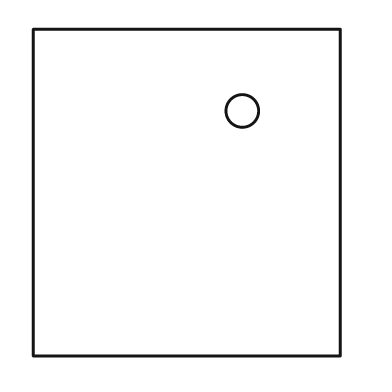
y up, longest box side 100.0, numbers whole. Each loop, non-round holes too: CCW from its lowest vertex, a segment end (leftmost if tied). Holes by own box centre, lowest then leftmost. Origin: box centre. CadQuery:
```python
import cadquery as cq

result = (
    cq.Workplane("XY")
    .moveTo(-47.0, -50.0)
    .lineTo(47.0, -50.0)
    .lineTo(47.0, 50.0)
    .lineTo(-47.0, 50.0)
    .close()
    .moveTo(17.0, 25.0)
    .circle(5.0)
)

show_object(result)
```